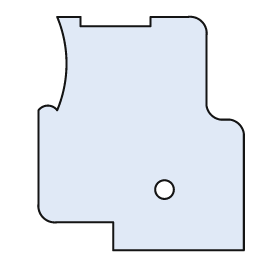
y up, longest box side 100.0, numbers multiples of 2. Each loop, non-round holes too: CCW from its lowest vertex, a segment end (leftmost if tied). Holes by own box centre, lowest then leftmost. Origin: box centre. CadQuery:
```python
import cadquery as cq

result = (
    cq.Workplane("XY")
    .moveTo(-12.0, -50.0)
    .lineTo(44.0, -50.0)
    .lineTo(44.0, 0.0)
    .threePointArc((42.0, 4.0), (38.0, 6.0))
    .lineTo(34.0, 6.0)
    .threePointArc((30.0, 8.0), (28.0, 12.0))
    .lineTo(28.0, 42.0)
    .threePointArc((26.0, 48.0), (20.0, 50.0))
    .lineTo(4.0, 50.0)
    .lineTo(4.0, 46.0)
    .lineTo(-26.0, 46.0)
    .lineTo(-26.0, 50.0)
    .lineTo(-36.0, 50.0)
    .threePointArc((-32.0, 30.0), (-36.0, 10.0))
    .threePointArc((-40.0, 12.0), (-44.0, 10.0))
    .lineTo(-44.0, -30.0)
    .threePointArc((-42.0, -36.0), (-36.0, -38.0))
    .lineTo(-12.0, -38.0)
    .close()
    .moveTo(10.0, -24.0)
    .circle(4.0)
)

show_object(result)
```